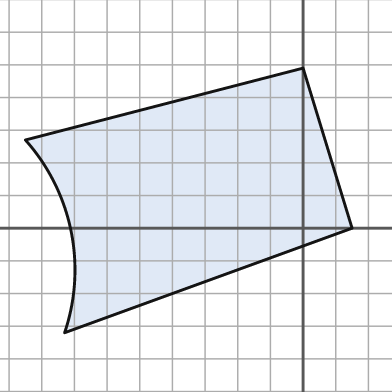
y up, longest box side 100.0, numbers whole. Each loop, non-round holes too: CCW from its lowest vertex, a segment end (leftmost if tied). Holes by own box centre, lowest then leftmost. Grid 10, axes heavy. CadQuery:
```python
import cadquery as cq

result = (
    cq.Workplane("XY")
    .moveTo(-73.0, -32.0)
    .lineTo(15.0, 0.0)
    .lineTo(0.0, 49.0)
    .lineTo(-85.0, 27.0)
    .threePointArc((-71.0, -1.0), (-73.0, -32.0))
    .close()
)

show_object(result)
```